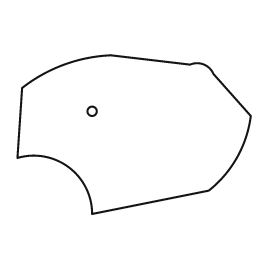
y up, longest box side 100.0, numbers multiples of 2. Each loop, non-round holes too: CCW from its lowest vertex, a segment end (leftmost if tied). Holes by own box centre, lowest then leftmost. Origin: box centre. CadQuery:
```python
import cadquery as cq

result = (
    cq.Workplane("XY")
    .moveTo(-18.0, -34.0)
    .lineTo(32.0, -24.0)
    .threePointArc((44.0, -10.0), (50.0, 8.0))
    .lineTo(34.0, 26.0)
    .threePointArc((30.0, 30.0), (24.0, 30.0))
    .lineTo(-10.0, 34.0)
    .threePointArc((-30.0, 30.0), (-48.0, 20.0))
    .lineTo(-50.0, -10.0)
    .threePointArc((-28.0, -14.0), (-18.0, -34.0))
    .close()
    .moveTo(-18.0, 10.0)
    .circle(2.0)
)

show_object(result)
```